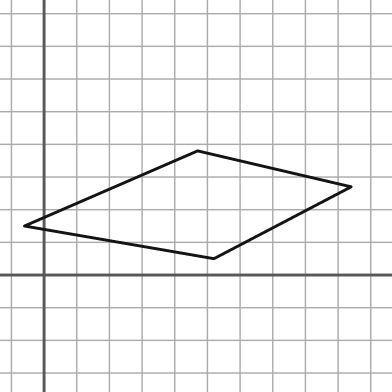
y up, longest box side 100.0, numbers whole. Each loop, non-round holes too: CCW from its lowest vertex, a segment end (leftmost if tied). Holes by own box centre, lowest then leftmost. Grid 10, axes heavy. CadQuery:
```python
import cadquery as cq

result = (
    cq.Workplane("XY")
    .moveTo(52.0, 5.0)
    .lineTo(94.0, 27.0)
    .lineTo(47.0, 38.0)
    .lineTo(-6.0, 15.0)
    .close()
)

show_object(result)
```